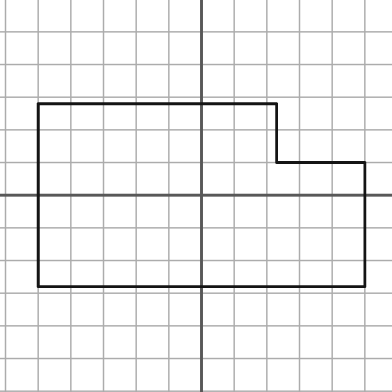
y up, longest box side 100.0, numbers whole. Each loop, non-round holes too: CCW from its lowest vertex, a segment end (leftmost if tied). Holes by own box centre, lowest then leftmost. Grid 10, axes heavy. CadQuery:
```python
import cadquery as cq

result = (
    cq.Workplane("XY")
    .moveTo(-50.0, -28.0)
    .lineTo(50.0, -28.0)
    .lineTo(50.0, 10.0)
    .lineTo(23.0, 10.0)
    .lineTo(23.0, 28.0)
    .lineTo(-50.0, 28.0)
    .close()
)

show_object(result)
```